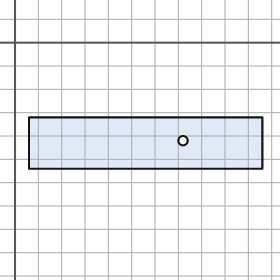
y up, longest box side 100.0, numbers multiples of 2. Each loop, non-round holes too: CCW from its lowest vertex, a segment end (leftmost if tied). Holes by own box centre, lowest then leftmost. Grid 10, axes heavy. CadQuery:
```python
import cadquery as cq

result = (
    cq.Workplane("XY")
    .moveTo(6.0, -54.0)
    .lineTo(106.0, -54.0)
    .lineTo(106.0, -32.0)
    .lineTo(6.0, -32.0)
    .close()
    .moveTo(72.0, -42.0)
    .circle(2.0)
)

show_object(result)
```